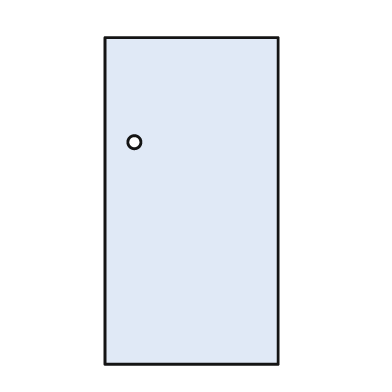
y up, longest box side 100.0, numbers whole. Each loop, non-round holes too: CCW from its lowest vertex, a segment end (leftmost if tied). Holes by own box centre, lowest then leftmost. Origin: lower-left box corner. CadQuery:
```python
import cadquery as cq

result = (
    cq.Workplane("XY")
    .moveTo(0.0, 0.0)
    .lineTo(53.0, 0.0)
    .lineTo(53.0, 100.0)
    .lineTo(0.0, 100.0)
    .close()
    .moveTo(9.0, 68.0)
    .circle(2.0)
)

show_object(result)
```